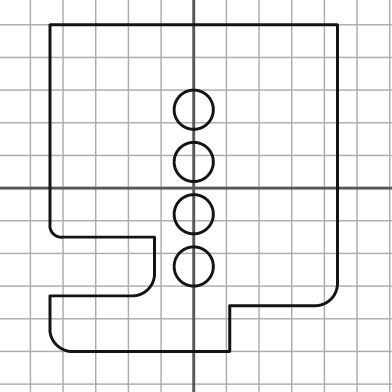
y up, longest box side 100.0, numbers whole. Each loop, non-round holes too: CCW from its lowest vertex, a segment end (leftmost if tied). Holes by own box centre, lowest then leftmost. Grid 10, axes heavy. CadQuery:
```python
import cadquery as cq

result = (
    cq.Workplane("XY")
    .moveTo(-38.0, -50.0)
    .lineTo(11.0, -50.0)
    .lineTo(11.0, -36.0)
    .lineTo(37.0, -36.0)
    .threePointArc((42.0, -34.0), (44.0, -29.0))
    .lineTo(44.0, 50.0)
    .lineTo(-44.0, 50.0)
    .lineTo(-44.0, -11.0)
    .threePointArc((-43.0, -14.0), (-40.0, -15.0))
    .lineTo(-12.0, -15.0)
    .lineTo(-12.0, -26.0)
    .threePointArc((-14.0, -31.0), (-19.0, -33.0))
    .lineTo(-44.0, -33.0)
    .lineTo(-44.0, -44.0)
    .threePointArc((-42.0, -48.0), (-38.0, -50.0))
    .close()
    .moveTo(0.0, -24.0)
    .circle(6.0)
    .moveTo(0.0, -8.0)
    .circle(6.0)
    .moveTo(0.0, 8.0)
    .circle(6.0)
    .moveTo(0.0, 24.0)
    .circle(6.0)
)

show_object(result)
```